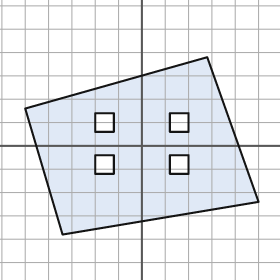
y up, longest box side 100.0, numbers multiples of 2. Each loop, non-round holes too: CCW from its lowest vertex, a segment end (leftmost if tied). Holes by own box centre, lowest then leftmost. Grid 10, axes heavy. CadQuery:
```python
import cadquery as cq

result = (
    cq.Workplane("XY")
    .moveTo(-34.0, -38.0)
    .lineTo(50.0, -24.0)
    .lineTo(28.0, 38.0)
    .lineTo(-50.0, 16.0)
    .close()
    .moveTo(-20.0, -12.0)
    .lineTo(-12.0, -12.0)
    .lineTo(-12.0, -4.0)
    .lineTo(-20.0, -4.0)
    .close()
    .moveTo(12.0, -12.0)
    .lineTo(20.0, -12.0)
    .lineTo(20.0, -4.0)
    .lineTo(12.0, -4.0)
    .close()
    .moveTo(-20.0, 6.0)
    .lineTo(-12.0, 6.0)
    .lineTo(-12.0, 14.0)
    .lineTo(-20.0, 14.0)
    .close()
    .moveTo(12.0, 6.0)
    .lineTo(20.0, 6.0)
    .lineTo(20.0, 14.0)
    .lineTo(12.0, 14.0)
    .close()
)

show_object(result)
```